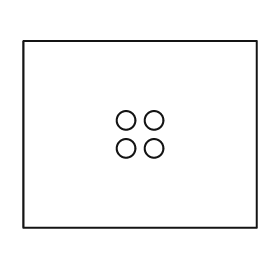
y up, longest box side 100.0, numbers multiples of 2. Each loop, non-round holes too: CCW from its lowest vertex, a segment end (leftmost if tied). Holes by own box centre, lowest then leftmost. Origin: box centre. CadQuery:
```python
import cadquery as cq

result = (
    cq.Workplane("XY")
    .moveTo(-50.0, -40.0)
    .lineTo(50.0, -40.0)
    .lineTo(50.0, 40.0)
    .lineTo(-50.0, 40.0)
    .close()
    .moveTo(-6.0, -6.0)
    .circle(4.0)
    .moveTo(6.0, -6.0)
    .circle(4.0)
    .moveTo(-6.0, 6.0)
    .circle(4.0)
    .moveTo(6.0, 6.0)
    .circle(4.0)
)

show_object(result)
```